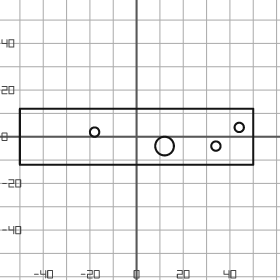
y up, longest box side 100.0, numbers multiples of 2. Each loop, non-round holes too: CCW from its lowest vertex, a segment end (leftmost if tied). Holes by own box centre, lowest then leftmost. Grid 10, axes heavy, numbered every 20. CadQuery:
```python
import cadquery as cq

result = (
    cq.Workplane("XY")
    .moveTo(-50.0, -12.0)
    .lineTo(50.0, -12.0)
    .lineTo(50.0, 12.0)
    .lineTo(-50.0, 12.0)
    .close()
    .moveTo(12.0, -4.0)
    .circle(4.0)
    .moveTo(34.0, -4.0)
    .circle(2.0)
    .moveTo(-18.0, 2.0)
    .circle(2.0)
    .moveTo(44.0, 4.0)
    .circle(2.0)
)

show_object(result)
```